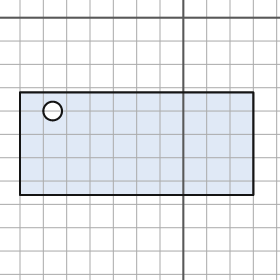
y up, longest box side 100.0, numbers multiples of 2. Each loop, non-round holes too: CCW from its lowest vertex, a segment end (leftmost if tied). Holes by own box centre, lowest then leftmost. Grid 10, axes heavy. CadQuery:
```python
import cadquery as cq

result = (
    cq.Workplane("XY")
    .moveTo(-70.0, -76.0)
    .lineTo(30.0, -76.0)
    .lineTo(30.0, -32.0)
    .lineTo(-70.0, -32.0)
    .close()
    .moveTo(-56.0, -40.0)
    .circle(4.0)
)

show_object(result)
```